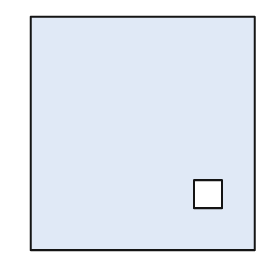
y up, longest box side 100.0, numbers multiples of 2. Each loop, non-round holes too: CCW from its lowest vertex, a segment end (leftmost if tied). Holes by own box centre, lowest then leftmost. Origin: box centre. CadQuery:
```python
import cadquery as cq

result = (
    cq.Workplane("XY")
    .moveTo(-48.0, -50.0)
    .lineTo(48.0, -50.0)
    .lineTo(48.0, 50.0)
    .lineTo(-48.0, 50.0)
    .close()
    .moveTo(22.0, -32.0)
    .lineTo(34.0, -32.0)
    .lineTo(34.0, -20.0)
    .lineTo(22.0, -20.0)
    .close()
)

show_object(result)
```